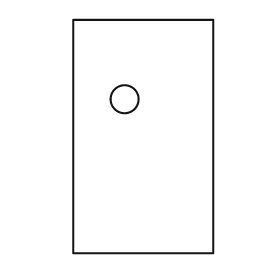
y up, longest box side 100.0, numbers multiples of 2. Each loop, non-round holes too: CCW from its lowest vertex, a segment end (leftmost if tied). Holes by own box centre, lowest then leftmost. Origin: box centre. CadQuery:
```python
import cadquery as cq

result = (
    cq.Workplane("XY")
    .moveTo(-30.0, -50.0)
    .lineTo(30.0, -50.0)
    .lineTo(30.0, 50.0)
    .lineTo(-30.0, 50.0)
    .close()
    .moveTo(-8.0, 16.0)
    .circle(6.0)
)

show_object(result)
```